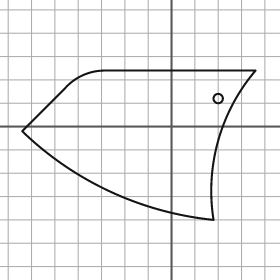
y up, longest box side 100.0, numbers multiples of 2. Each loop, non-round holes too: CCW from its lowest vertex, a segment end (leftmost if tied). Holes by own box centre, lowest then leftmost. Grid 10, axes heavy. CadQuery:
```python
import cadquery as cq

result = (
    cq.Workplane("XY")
    .moveTo(18.0, -40.0)
    .threePointArc((20.0, -6.0), (36.0, 24.0))
    .lineTo(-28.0, 24.0)
    .threePointArc((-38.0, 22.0), (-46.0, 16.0))
    .lineTo(-64.0, -2.0)
    .threePointArc((-26.0, -28.0), (18.0, -40.0))
    .close()
    .moveTo(20.0, 12.0)
    .circle(2.0)
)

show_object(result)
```